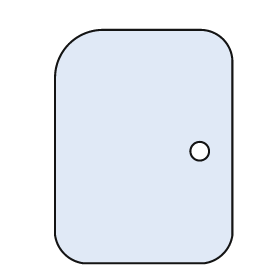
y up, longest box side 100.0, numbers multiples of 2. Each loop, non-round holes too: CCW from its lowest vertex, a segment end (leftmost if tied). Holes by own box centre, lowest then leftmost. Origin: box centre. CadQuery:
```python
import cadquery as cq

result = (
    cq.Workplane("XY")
    .moveTo(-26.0, -50.0)
    .lineTo(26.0, -50.0)
    .threePointArc((34.0, -46.0), (38.0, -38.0))
    .lineTo(38.0, 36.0)
    .threePointArc((34.0, 46.0), (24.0, 50.0))
    .lineTo(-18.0, 50.0)
    .threePointArc((-32.0, 44.0), (-38.0, 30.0))
    .lineTo(-38.0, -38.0)
    .threePointArc((-34.0, -46.0), (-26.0, -50.0))
    .close()
    .moveTo(24.0, -2.0)
    .circle(4.0)
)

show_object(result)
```